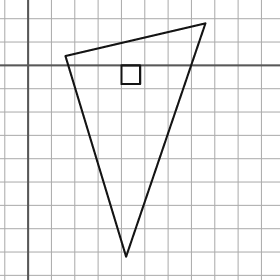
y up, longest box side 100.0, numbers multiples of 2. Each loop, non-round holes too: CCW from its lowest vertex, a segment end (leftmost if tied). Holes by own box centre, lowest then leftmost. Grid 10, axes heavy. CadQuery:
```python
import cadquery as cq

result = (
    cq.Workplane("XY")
    .moveTo(42.0, -82.0)
    .lineTo(76.0, 18.0)
    .lineTo(16.0, 4.0)
    .close()
    .moveTo(40.0, -8.0)
    .lineTo(48.0, -8.0)
    .lineTo(48.0, 0.0)
    .lineTo(40.0, 0.0)
    .close()
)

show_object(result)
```